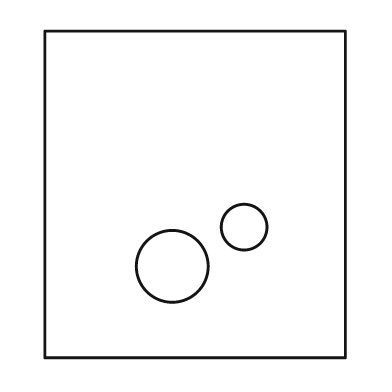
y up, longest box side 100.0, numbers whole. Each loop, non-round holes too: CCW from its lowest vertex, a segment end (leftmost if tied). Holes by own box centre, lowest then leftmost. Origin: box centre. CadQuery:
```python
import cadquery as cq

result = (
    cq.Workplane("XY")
    .moveTo(-46.0, -50.0)
    .lineTo(46.0, -50.0)
    .lineTo(46.0, 50.0)
    .lineTo(-46.0, 50.0)
    .close()
    .moveTo(-7.0, -22.0)
    .circle(11.0)
    .moveTo(15.0, -10.0)
    .circle(7.0)
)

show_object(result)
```